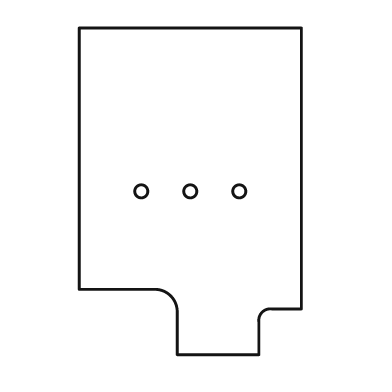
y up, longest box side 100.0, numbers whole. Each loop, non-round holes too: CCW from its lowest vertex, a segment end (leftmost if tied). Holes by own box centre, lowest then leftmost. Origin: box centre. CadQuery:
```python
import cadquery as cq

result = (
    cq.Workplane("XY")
    .moveTo(-4.0, -50.0)
    .lineTo(21.0, -50.0)
    .lineTo(21.0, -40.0)
    .threePointArc((22.0, -37.0), (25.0, -36.0))
    .lineTo(34.0, -36.0)
    .lineTo(34.0, 50.0)
    .lineTo(-34.0, 50.0)
    .lineTo(-34.0, -30.0)
    .lineTo(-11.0, -30.0)
    .threePointArc((-6.0, -32.0), (-4.0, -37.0))
    .close()
    .moveTo(-15.0, 0.0)
    .circle(2.0)
    .moveTo(0.0, 0.0)
    .circle(2.0)
    .moveTo(15.0, 0.0)
    .circle(2.0)
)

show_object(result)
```